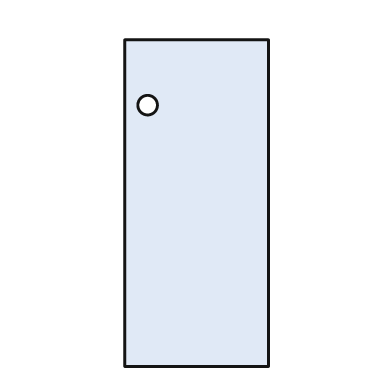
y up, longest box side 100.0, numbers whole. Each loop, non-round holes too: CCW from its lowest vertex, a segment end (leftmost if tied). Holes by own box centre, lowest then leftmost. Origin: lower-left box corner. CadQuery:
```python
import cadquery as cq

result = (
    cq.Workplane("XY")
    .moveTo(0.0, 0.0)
    .lineTo(44.0, 0.0)
    .lineTo(44.0, 100.0)
    .lineTo(0.0, 100.0)
    .close()
    .moveTo(7.0, 80.0)
    .circle(3.0)
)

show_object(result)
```